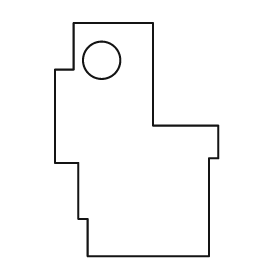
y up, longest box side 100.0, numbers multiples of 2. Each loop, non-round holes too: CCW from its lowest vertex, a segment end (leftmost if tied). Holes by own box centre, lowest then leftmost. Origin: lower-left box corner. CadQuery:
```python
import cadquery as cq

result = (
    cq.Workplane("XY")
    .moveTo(14.0, 0.0)
    .lineTo(66.0, 0.0)
    .lineTo(66.0, 42.0)
    .lineTo(70.0, 42.0)
    .lineTo(70.0, 56.0)
    .lineTo(42.0, 56.0)
    .lineTo(42.0, 100.0)
    .lineTo(8.0, 100.0)
    .lineTo(8.0, 80.0)
    .lineTo(0.0, 80.0)
    .lineTo(0.0, 40.0)
    .lineTo(10.0, 40.0)
    .lineTo(10.0, 16.0)
    .lineTo(14.0, 16.0)
    .close()
    .moveTo(20.0, 84.0)
    .circle(8.0)
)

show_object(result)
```